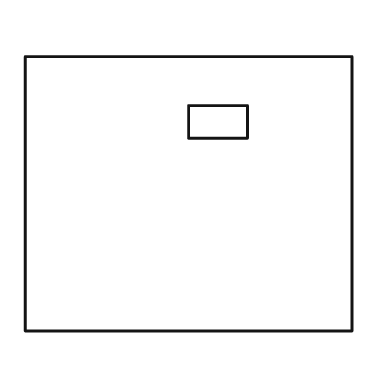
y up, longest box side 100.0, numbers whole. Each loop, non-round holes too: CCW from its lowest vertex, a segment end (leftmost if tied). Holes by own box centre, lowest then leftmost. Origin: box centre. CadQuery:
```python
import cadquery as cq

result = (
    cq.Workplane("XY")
    .moveTo(-50.0, -42.0)
    .lineTo(50.0, -42.0)
    .lineTo(50.0, 42.0)
    .lineTo(-50.0, 42.0)
    .close()
    .moveTo(0.0, 17.0)
    .lineTo(18.0, 17.0)
    .lineTo(18.0, 27.0)
    .lineTo(0.0, 27.0)
    .close()
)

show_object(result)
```